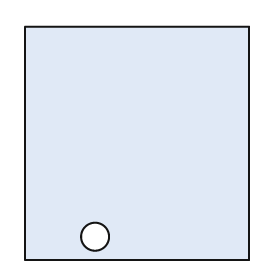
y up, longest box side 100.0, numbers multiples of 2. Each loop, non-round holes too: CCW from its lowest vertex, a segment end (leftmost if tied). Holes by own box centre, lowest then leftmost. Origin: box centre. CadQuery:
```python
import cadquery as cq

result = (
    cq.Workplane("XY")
    .moveTo(-48.0, -50.0)
    .lineTo(48.0, -50.0)
    .lineTo(48.0, 50.0)
    .lineTo(-48.0, 50.0)
    .close()
    .moveTo(-18.0, -40.0)
    .circle(6.0)
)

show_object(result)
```